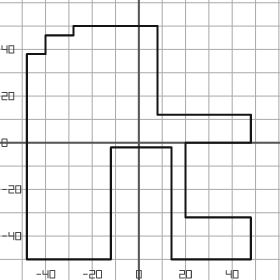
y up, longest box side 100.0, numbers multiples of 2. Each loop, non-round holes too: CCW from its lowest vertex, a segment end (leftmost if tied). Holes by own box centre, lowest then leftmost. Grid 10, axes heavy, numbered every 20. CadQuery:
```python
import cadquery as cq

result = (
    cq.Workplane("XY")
    .moveTo(-48.0, -50.0)
    .lineTo(-12.0, -50.0)
    .lineTo(-12.0, -2.0)
    .lineTo(14.0, -2.0)
    .lineTo(14.0, -50.0)
    .lineTo(48.0, -50.0)
    .lineTo(48.0, -32.0)
    .lineTo(20.0, -32.0)
    .lineTo(20.0, 0.0)
    .lineTo(48.0, 0.0)
    .lineTo(48.0, 12.0)
    .lineTo(8.0, 12.0)
    .lineTo(8.0, 50.0)
    .lineTo(-28.0, 50.0)
    .lineTo(-28.0, 46.0)
    .lineTo(-40.0, 46.0)
    .lineTo(-40.0, 38.0)
    .lineTo(-48.0, 38.0)
    .close()
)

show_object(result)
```